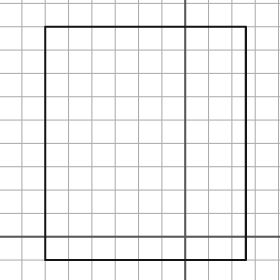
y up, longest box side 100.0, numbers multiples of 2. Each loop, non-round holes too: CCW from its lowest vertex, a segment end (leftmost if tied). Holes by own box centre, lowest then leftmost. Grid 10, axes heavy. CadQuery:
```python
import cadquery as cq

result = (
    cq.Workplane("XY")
    .moveTo(-60.0, -10.0)
    .lineTo(26.0, -10.0)
    .lineTo(26.0, 90.0)
    .lineTo(-60.0, 90.0)
    .close()
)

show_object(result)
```